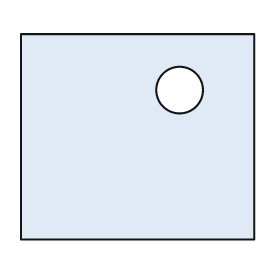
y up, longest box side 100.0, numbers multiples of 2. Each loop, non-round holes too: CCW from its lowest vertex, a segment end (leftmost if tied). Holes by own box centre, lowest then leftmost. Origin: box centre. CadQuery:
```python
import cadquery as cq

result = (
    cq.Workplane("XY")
    .moveTo(-50.0, -44.0)
    .lineTo(50.0, -44.0)
    .lineTo(50.0, 44.0)
    .lineTo(-50.0, 44.0)
    .close()
    .moveTo(18.0, 20.0)
    .circle(10.0)
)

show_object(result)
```